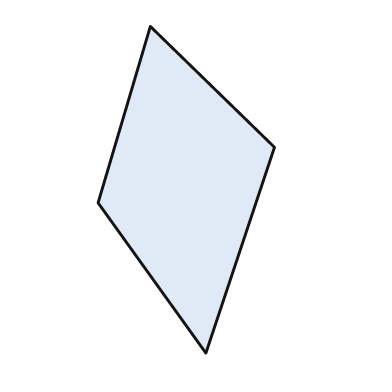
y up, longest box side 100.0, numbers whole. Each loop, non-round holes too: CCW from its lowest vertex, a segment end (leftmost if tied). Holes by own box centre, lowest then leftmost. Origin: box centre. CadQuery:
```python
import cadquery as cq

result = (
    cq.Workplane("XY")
    .moveTo(6.0, -50.0)
    .lineTo(27.0, 13.0)
    .lineTo(-11.0, 50.0)
    .lineTo(-27.0, -4.0)
    .close()
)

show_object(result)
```